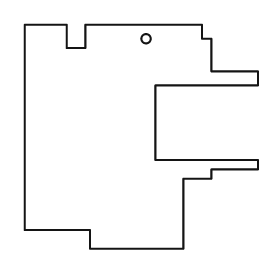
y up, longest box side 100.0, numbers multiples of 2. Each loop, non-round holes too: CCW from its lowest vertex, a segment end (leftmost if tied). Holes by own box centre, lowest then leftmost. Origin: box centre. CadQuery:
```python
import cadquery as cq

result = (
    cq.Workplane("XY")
    .moveTo(-22.0, -48.0)
    .lineTo(18.0, -48.0)
    .lineTo(18.0, -18.0)
    .lineTo(30.0, -18.0)
    .lineTo(30.0, -14.0)
    .lineTo(50.0, -14.0)
    .lineTo(50.0, -10.0)
    .lineTo(6.0, -10.0)
    .lineTo(6.0, 22.0)
    .lineTo(50.0, 22.0)
    .lineTo(50.0, 28.0)
    .lineTo(30.0, 28.0)
    .lineTo(30.0, 42.0)
    .lineTo(26.0, 42.0)
    .lineTo(26.0, 48.0)
    .lineTo(-24.0, 48.0)
    .lineTo(-24.0, 38.0)
    .lineTo(-32.0, 38.0)
    .lineTo(-32.0, 48.0)
    .lineTo(-50.0, 48.0)
    .lineTo(-50.0, -40.0)
    .lineTo(-22.0, -40.0)
    .close()
    .moveTo(2.0, 42.0)
    .circle(2.0)
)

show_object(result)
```